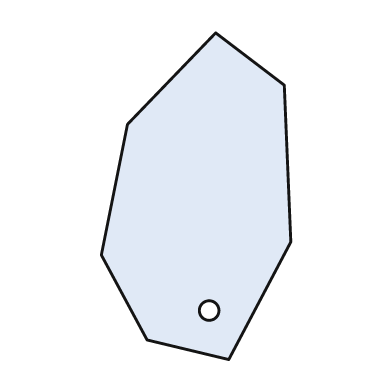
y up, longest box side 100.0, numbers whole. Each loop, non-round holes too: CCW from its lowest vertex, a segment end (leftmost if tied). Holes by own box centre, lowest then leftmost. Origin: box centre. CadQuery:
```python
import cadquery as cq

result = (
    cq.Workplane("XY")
    .moveTo(10.0, -50.0)
    .lineTo(29.0, -14.0)
    .lineTo(27.0, 34.0)
    .lineTo(6.0, 50.0)
    .lineTo(-21.0, 22.0)
    .lineTo(-29.0, -18.0)
    .lineTo(-15.0, -44.0)
    .close()
    .moveTo(4.0, -35.0)
    .circle(3.0)
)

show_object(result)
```